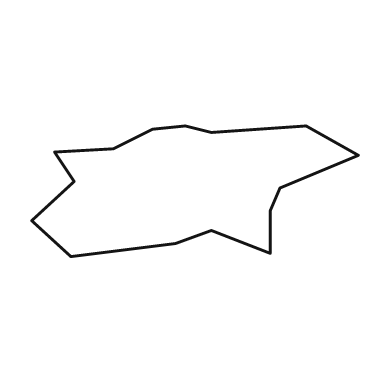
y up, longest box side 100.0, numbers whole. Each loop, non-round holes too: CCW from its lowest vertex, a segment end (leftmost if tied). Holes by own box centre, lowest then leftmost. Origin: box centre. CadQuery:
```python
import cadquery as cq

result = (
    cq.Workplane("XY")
    .moveTo(-38.0, -20.0)
    .lineTo(-6.0, -16.0)
    .lineTo(5.0, -12.0)
    .lineTo(23.0, -19.0)
    .lineTo(23.0, -6.0)
    .lineTo(26.0, 1.0)
    .lineTo(50.0, 11.0)
    .lineTo(34.0, 20.0)
    .lineTo(5.0, 18.0)
    .lineTo(-3.0, 20.0)
    .lineTo(-13.0, 19.0)
    .lineTo(-25.0, 13.0)
    .lineTo(-43.0, 12.0)
    .lineTo(-37.0, 3.0)
    .lineTo(-50.0, -9.0)
    .close()
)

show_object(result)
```